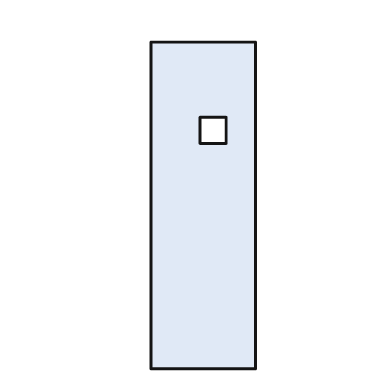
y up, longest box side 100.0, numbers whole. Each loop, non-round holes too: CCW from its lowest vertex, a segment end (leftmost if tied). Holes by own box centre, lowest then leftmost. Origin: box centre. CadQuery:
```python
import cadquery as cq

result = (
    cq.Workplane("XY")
    .moveTo(-16.0, -50.0)
    .lineTo(16.0, -50.0)
    .lineTo(16.0, 50.0)
    .lineTo(-16.0, 50.0)
    .close()
    .moveTo(-1.0, 19.0)
    .lineTo(7.0, 19.0)
    .lineTo(7.0, 27.0)
    .lineTo(-1.0, 27.0)
    .close()
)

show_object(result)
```